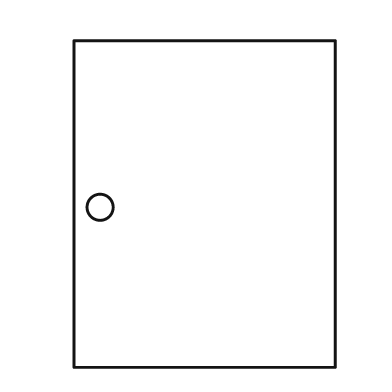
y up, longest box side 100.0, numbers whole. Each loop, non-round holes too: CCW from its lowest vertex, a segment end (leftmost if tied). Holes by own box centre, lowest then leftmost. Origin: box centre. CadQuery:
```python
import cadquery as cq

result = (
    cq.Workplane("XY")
    .moveTo(-40.0, -50.0)
    .lineTo(40.0, -50.0)
    .lineTo(40.0, 50.0)
    .lineTo(-40.0, 50.0)
    .close()
    .moveTo(-32.0, -1.0)
    .circle(4.0)
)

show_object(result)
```